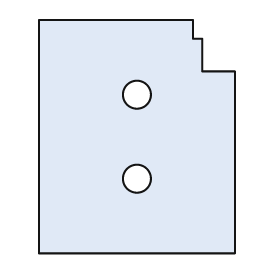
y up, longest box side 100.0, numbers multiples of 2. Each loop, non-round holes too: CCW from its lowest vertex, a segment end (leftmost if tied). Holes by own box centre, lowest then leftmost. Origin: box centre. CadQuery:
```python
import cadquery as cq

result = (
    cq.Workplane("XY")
    .moveTo(-42.0, -50.0)
    .lineTo(42.0, -50.0)
    .lineTo(42.0, 28.0)
    .lineTo(28.0, 28.0)
    .lineTo(28.0, 42.0)
    .lineTo(24.0, 42.0)
    .lineTo(24.0, 50.0)
    .lineTo(-42.0, 50.0)
    .close()
    .moveTo(0.0, -18.0)
    .circle(6.0)
    .moveTo(0.0, 18.0)
    .circle(6.0)
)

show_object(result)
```